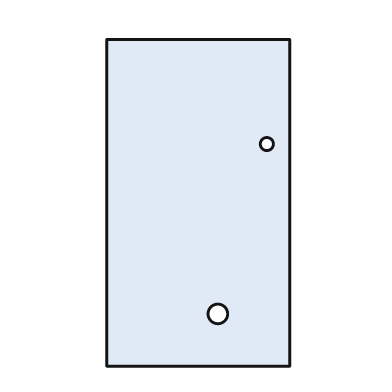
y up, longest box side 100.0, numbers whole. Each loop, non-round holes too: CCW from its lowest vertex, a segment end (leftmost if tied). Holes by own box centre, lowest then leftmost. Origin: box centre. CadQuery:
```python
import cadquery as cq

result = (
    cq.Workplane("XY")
    .moveTo(-28.0, -50.0)
    .lineTo(28.0, -50.0)
    .lineTo(28.0, 50.0)
    .lineTo(-28.0, 50.0)
    .close()
    .moveTo(6.0, -34.0)
    .circle(3.0)
    .moveTo(21.0, 18.0)
    .circle(2.0)
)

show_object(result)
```